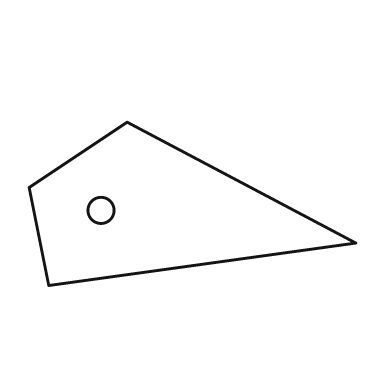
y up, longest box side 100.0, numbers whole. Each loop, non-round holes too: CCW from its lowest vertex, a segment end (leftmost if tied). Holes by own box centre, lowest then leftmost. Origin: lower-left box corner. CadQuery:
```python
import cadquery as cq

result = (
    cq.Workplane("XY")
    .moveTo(6.0, 0.0)
    .lineTo(100.0, 13.0)
    .lineTo(30.0, 50.0)
    .lineTo(0.0, 30.0)
    .close()
    .moveTo(22.0, 23.0)
    .circle(4.0)
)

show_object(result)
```